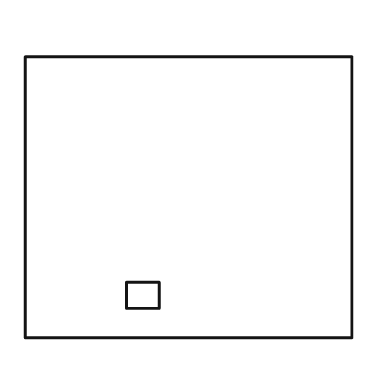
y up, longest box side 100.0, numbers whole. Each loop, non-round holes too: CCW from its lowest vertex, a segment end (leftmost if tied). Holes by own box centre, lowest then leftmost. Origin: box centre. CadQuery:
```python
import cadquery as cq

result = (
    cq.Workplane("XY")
    .moveTo(-50.0, -43.0)
    .lineTo(50.0, -43.0)
    .lineTo(50.0, 43.0)
    .lineTo(-50.0, 43.0)
    .close()
    .moveTo(-19.0, -34.0)
    .lineTo(-9.0, -34.0)
    .lineTo(-9.0, -26.0)
    .lineTo(-19.0, -26.0)
    .close()
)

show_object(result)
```